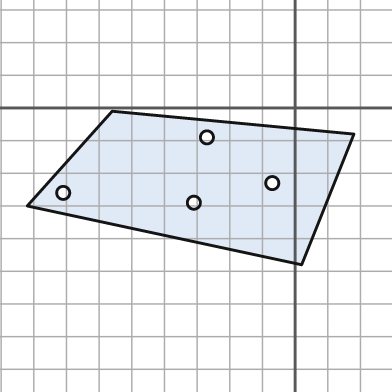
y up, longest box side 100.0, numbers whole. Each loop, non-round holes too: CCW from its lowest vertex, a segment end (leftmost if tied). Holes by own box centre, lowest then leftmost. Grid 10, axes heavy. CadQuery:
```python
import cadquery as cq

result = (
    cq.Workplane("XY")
    .moveTo(2.0, -48.0)
    .lineTo(18.0, -8.0)
    .lineTo(-56.0, -1.0)
    .lineTo(-82.0, -30.0)
    .close()
    .moveTo(-31.0, -29.0)
    .circle(2.0)
    .moveTo(-71.0, -26.0)
    .circle(2.0)
    .moveTo(-7.0, -23.0)
    .circle(2.0)
    .moveTo(-27.0, -9.0)
    .circle(2.0)
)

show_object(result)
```